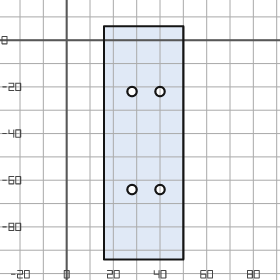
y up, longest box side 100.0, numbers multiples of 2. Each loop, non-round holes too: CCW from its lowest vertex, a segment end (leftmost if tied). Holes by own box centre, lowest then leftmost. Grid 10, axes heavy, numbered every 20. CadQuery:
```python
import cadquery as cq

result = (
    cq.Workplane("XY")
    .moveTo(16.0, -94.0)
    .lineTo(50.0, -94.0)
    .lineTo(50.0, 6.0)
    .lineTo(16.0, 6.0)
    .close()
    .moveTo(28.0, -64.0)
    .circle(2.0)
    .moveTo(40.0, -64.0)
    .circle(2.0)
    .moveTo(28.0, -22.0)
    .circle(2.0)
    .moveTo(40.0, -22.0)
    .circle(2.0)
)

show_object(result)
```